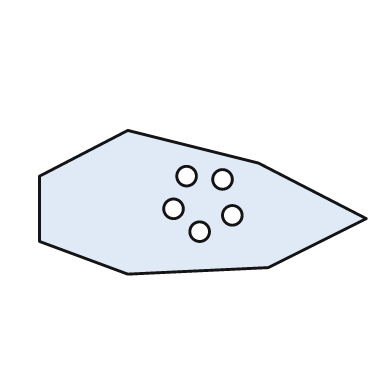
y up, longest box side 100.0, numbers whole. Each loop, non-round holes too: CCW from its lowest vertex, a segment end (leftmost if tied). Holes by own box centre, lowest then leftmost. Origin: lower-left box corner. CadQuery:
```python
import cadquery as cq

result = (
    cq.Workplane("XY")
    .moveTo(27.0, 0.0)
    .lineTo(70.0, 2.0)
    .lineTo(100.0, 17.0)
    .lineTo(67.0, 34.0)
    .lineTo(27.0, 44.0)
    .lineTo(0.0, 30.0)
    .lineTo(0.0, 10.0)
    .close()
    .moveTo(49.0, 13.0)
    .circle(3.0)
    .moveTo(59.0, 18.0)
    .circle(3.0)
    .moveTo(41.0, 20.0)
    .circle(3.0)
    .moveTo(56.0, 29.0)
    .circle(3.0)
    .moveTo(45.0, 30.0)
    .circle(3.0)
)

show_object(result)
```